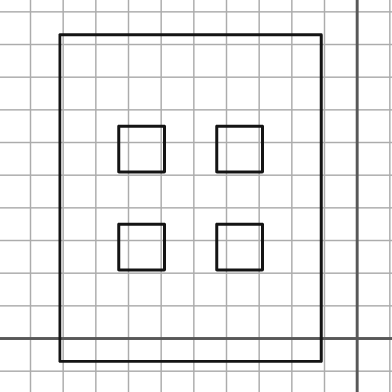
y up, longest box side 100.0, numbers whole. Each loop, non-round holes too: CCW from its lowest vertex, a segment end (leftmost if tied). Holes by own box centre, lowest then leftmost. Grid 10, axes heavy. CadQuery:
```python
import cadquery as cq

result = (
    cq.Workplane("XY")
    .moveTo(-91.0, -7.0)
    .lineTo(-11.0, -7.0)
    .lineTo(-11.0, 93.0)
    .lineTo(-91.0, 93.0)
    .close()
    .moveTo(-73.0, 21.0)
    .lineTo(-59.0, 21.0)
    .lineTo(-59.0, 35.0)
    .lineTo(-73.0, 35.0)
    .close()
    .moveTo(-43.0, 21.0)
    .lineTo(-29.0, 21.0)
    .lineTo(-29.0, 35.0)
    .lineTo(-43.0, 35.0)
    .close()
    .moveTo(-73.0, 51.0)
    .lineTo(-59.0, 51.0)
    .lineTo(-59.0, 65.0)
    .lineTo(-73.0, 65.0)
    .close()
    .moveTo(-43.0, 51.0)
    .lineTo(-29.0, 51.0)
    .lineTo(-29.0, 65.0)
    .lineTo(-43.0, 65.0)
    .close()
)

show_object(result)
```